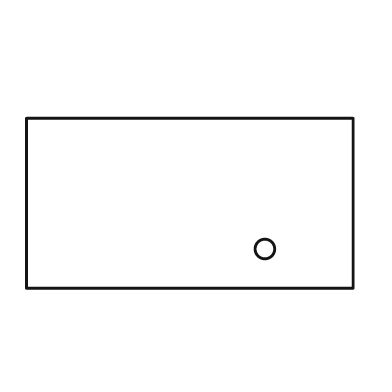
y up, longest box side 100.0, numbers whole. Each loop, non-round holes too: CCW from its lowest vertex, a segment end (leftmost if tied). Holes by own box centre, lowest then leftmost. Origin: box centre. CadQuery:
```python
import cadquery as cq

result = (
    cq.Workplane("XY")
    .moveTo(-50.0, -26.0)
    .lineTo(50.0, -26.0)
    .lineTo(50.0, 26.0)
    .lineTo(-50.0, 26.0)
    .close()
    .moveTo(23.0, -14.0)
    .circle(3.0)
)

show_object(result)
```